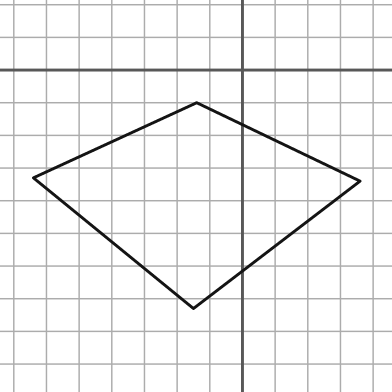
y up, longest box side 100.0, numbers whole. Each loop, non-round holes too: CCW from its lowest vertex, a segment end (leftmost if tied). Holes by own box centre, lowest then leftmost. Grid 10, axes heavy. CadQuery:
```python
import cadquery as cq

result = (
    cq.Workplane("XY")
    .moveTo(-15.0, -73.0)
    .lineTo(36.0, -34.0)
    .lineTo(-14.0, -10.0)
    .lineTo(-64.0, -33.0)
    .close()
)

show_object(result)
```